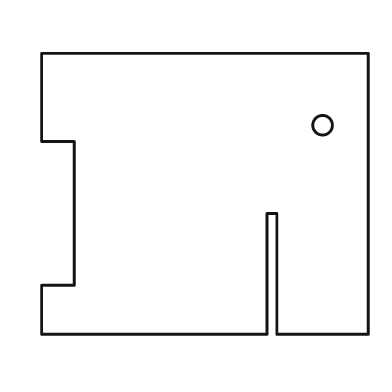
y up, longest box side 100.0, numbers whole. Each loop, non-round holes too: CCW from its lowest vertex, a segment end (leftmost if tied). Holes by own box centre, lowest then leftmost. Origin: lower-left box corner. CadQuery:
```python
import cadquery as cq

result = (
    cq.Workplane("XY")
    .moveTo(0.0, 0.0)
    .lineTo(69.0, 0.0)
    .lineTo(69.0, 37.0)
    .lineTo(72.0, 37.0)
    .lineTo(72.0, 0.0)
    .lineTo(100.0, 0.0)
    .lineTo(100.0, 86.0)
    .lineTo(0.0, 86.0)
    .lineTo(0.0, 59.0)
    .lineTo(10.0, 59.0)
    .lineTo(10.0, 15.0)
    .lineTo(0.0, 15.0)
    .close()
    .moveTo(86.0, 64.0)
    .circle(3.0)
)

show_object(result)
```